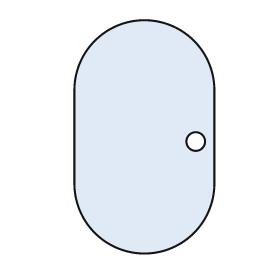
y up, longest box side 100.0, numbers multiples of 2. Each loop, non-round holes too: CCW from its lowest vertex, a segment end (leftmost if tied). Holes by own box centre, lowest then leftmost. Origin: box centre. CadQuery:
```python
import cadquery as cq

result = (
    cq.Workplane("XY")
    .moveTo(-30.0, -20.0)
    .threePointArc((0.0, -50.0), (30.0, -20.0))
    .lineTo(30.0, 20.0)
    .threePointArc((0.0, 50.0), (-30.0, 20.0))
    .close()
    .moveTo(22.0, -2.0)
    .circle(4.0)
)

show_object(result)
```